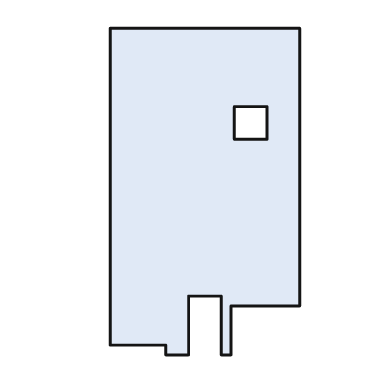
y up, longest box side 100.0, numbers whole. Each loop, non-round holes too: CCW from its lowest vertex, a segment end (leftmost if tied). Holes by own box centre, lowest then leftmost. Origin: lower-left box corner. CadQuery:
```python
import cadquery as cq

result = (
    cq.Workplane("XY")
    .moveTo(17.0, 0.0)
    .lineTo(24.0, 0.0)
    .lineTo(24.0, 18.0)
    .lineTo(34.0, 18.0)
    .lineTo(34.0, 0.0)
    .lineTo(37.0, 0.0)
    .lineTo(37.0, 15.0)
    .lineTo(58.0, 15.0)
    .lineTo(58.0, 100.0)
    .lineTo(0.0, 100.0)
    .lineTo(0.0, 3.0)
    .lineTo(17.0, 3.0)
    .close()
    .moveTo(38.0, 66.0)
    .lineTo(48.0, 66.0)
    .lineTo(48.0, 76.0)
    .lineTo(38.0, 76.0)
    .close()
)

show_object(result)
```